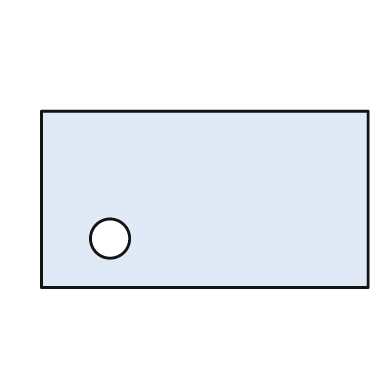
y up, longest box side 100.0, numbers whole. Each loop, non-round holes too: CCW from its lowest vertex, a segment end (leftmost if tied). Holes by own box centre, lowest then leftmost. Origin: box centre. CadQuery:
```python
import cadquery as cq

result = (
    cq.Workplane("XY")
    .moveTo(-50.0, -27.0)
    .lineTo(50.0, -27.0)
    .lineTo(50.0, 27.0)
    .lineTo(-50.0, 27.0)
    .close()
    .moveTo(-29.0, -12.0)
    .circle(6.0)
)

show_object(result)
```